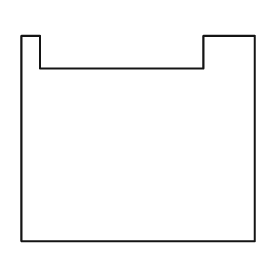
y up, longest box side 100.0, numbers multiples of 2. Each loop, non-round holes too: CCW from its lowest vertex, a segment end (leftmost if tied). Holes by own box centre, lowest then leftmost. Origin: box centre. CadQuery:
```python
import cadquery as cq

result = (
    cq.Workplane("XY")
    .moveTo(-50.0, -44.0)
    .lineTo(50.0, -44.0)
    .lineTo(50.0, 44.0)
    .lineTo(28.0, 44.0)
    .lineTo(28.0, 30.0)
    .lineTo(-42.0, 30.0)
    .lineTo(-42.0, 44.0)
    .lineTo(-50.0, 44.0)
    .close()
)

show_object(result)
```